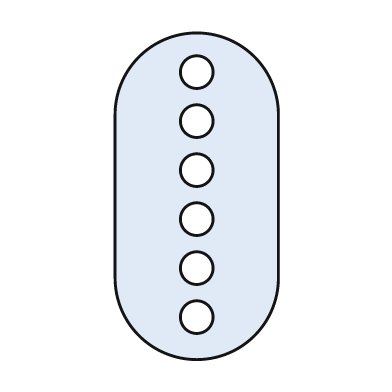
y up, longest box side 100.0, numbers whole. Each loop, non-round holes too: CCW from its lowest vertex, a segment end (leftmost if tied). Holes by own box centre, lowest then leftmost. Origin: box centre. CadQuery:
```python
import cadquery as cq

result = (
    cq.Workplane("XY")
    .moveTo(-25.0, -25.0)
    .threePointArc((0.0, -50.0), (25.0, -25.0))
    .lineTo(25.0, 25.0)
    .threePointArc((0.0, 50.0), (-25.0, 25.0))
    .close()
    .moveTo(0.0, -37.0)
    .circle(5.0)
    .moveTo(0.0, -22.0)
    .circle(5.0)
    .moveTo(0.0, -7.0)
    .circle(5.0)
    .moveTo(0.0, 8.0)
    .circle(5.0)
    .moveTo(0.0, 23.0)
    .circle(5.0)
    .moveTo(0.0, 38.0)
    .circle(5.0)
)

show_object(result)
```